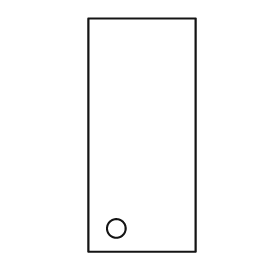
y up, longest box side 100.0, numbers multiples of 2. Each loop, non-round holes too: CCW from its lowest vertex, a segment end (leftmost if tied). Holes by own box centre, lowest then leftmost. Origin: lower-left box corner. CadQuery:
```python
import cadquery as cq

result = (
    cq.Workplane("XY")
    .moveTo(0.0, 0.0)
    .lineTo(46.0, 0.0)
    .lineTo(46.0, 100.0)
    .lineTo(0.0, 100.0)
    .close()
    .moveTo(12.0, 10.0)
    .circle(4.0)
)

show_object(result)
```